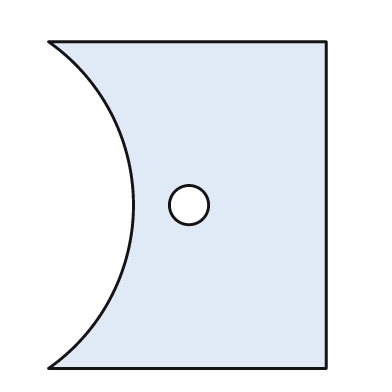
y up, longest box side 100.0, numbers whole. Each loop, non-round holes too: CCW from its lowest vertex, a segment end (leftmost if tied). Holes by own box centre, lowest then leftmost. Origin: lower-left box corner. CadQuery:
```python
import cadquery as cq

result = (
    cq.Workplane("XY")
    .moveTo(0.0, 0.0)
    .lineTo(85.0, 0.0)
    .lineTo(85.0, 100.0)
    .lineTo(0.0, 100.0)
    .threePointArc((26.0, 50.0), (0.0, 0.0))
    .close()
    .moveTo(43.0, 50.0)
    .circle(6.0)
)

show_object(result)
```